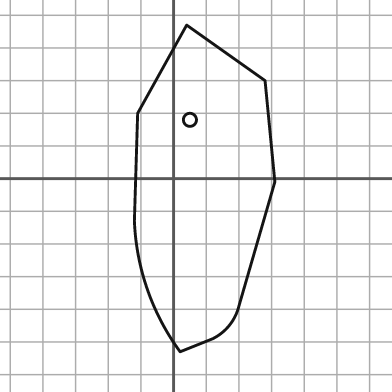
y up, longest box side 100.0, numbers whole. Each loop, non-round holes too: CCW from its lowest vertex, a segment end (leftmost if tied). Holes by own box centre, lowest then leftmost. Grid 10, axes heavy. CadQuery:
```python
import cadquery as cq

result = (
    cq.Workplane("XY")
    .moveTo(2.0, -53.0)
    .lineTo(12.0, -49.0)
    .threePointArc((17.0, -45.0), (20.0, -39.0))
    .lineTo(31.0, -1.0)
    .lineTo(28.0, 30.0)
    .lineTo(4.0, 47.0)
    .lineTo(-11.0, 20.0)
    .lineTo(-12.0, -13.0)
    .threePointArc((-8.0, -34.0), (2.0, -53.0))
    .close()
    .moveTo(5.0, 18.0)
    .circle(2.0)
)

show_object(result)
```